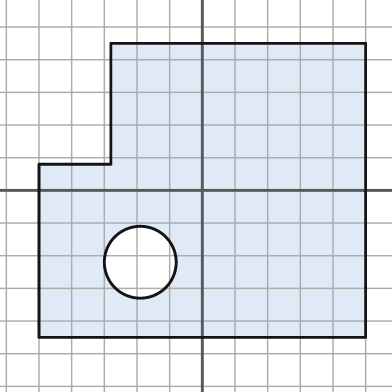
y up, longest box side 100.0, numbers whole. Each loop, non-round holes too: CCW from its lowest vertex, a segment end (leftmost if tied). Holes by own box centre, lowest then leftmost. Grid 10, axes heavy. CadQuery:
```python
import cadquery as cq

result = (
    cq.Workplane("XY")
    .moveTo(-50.0, -45.0)
    .lineTo(50.0, -45.0)
    .lineTo(50.0, 45.0)
    .lineTo(-28.0, 45.0)
    .lineTo(-28.0, 8.0)
    .lineTo(-50.0, 8.0)
    .close()
    .moveTo(-19.0, -22.0)
    .circle(11.0)
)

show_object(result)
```